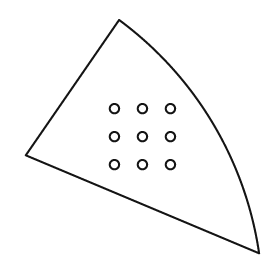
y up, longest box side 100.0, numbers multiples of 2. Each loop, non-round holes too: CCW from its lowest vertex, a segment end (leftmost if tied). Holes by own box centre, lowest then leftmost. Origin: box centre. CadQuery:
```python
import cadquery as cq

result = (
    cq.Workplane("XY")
    .moveTo(50.0, -50.0)
    .threePointArc((30.0, 6.0), (-10.0, 50.0))
    .lineTo(-50.0, -8.0)
    .close()
    .moveTo(-12.0, -12.0)
    .circle(2.0)
    .moveTo(0.0, -12.0)
    .circle(2.0)
    .moveTo(12.0, -12.0)
    .circle(2.0)
    .moveTo(-12.0, 0.0)
    .circle(2.0)
    .moveTo(0.0, 0.0)
    .circle(2.0)
    .moveTo(12.0, 0.0)
    .circle(2.0)
    .moveTo(-12.0, 12.0)
    .circle(2.0)
    .moveTo(0.0, 12.0)
    .circle(2.0)
    .moveTo(12.0, 12.0)
    .circle(2.0)
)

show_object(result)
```